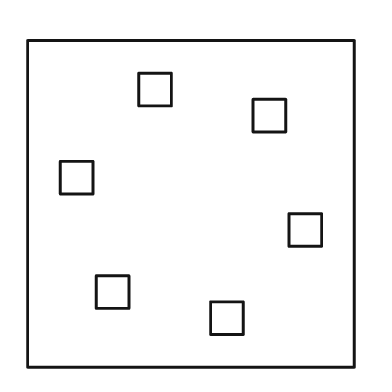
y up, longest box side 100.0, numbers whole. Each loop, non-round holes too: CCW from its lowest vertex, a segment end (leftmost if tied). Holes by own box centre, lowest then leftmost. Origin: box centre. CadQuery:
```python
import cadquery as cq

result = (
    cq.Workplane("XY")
    .moveTo(-50.0, -50.0)
    .lineTo(50.0, -50.0)
    .lineTo(50.0, 50.0)
    .lineTo(-50.0, 50.0)
    .close()
    .moveTo(6.0, -40.0)
    .lineTo(16.0, -40.0)
    .lineTo(16.0, -30.0)
    .lineTo(6.0, -30.0)
    .close()
    .moveTo(-29.0, -32.0)
    .lineTo(-19.0, -32.0)
    .lineTo(-19.0, -22.0)
    .lineTo(-29.0, -22.0)
    .close()
    .moveTo(30.0, -13.0)
    .lineTo(40.0, -13.0)
    .lineTo(40.0, -3.0)
    .lineTo(30.0, -3.0)
    .close()
    .moveTo(-40.0, 3.0)
    .lineTo(-30.0, 3.0)
    .lineTo(-30.0, 13.0)
    .lineTo(-40.0, 13.0)
    .close()
    .moveTo(19.0, 22.0)
    .lineTo(29.0, 22.0)
    .lineTo(29.0, 32.0)
    .lineTo(19.0, 32.0)
    .close()
    .moveTo(-16.0, 30.0)
    .lineTo(-6.0, 30.0)
    .lineTo(-6.0, 40.0)
    .lineTo(-16.0, 40.0)
    .close()
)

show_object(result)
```